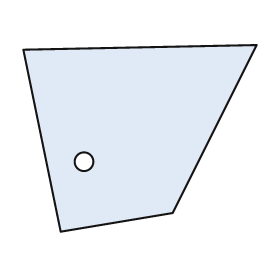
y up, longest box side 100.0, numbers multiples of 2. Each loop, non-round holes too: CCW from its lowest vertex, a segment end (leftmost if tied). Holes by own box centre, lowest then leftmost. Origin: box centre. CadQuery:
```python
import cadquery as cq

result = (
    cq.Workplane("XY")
    .moveTo(-34.0, -40.0)
    .lineTo(14.0, -32.0)
    .lineTo(50.0, 40.0)
    .lineTo(-50.0, 38.0)
    .close()
    .moveTo(-24.0, -10.0)
    .circle(4.0)
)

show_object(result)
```